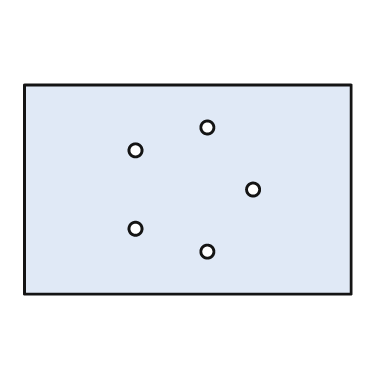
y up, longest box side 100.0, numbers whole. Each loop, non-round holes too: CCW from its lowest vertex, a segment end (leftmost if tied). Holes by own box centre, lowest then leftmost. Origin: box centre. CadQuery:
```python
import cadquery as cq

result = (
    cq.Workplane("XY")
    .moveTo(-50.0, -32.0)
    .lineTo(50.0, -32.0)
    .lineTo(50.0, 32.0)
    .lineTo(-50.0, 32.0)
    .close()
    .moveTo(6.0, -19.0)
    .circle(2.0)
    .moveTo(-16.0, -12.0)
    .circle(2.0)
    .moveTo(20.0, 0.0)
    .circle(2.0)
    .moveTo(-16.0, 12.0)
    .circle(2.0)
    .moveTo(6.0, 19.0)
    .circle(2.0)
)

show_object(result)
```